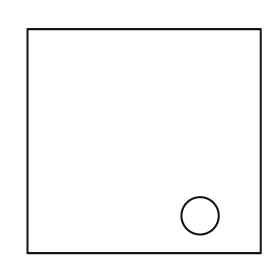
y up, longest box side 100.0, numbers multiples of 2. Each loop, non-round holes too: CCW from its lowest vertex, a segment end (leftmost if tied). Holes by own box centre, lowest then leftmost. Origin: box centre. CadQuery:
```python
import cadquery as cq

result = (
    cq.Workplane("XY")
    .moveTo(-50.0, -48.0)
    .lineTo(50.0, -48.0)
    .lineTo(50.0, 48.0)
    .lineTo(-50.0, 48.0)
    .close()
    .moveTo(24.0, -32.0)
    .circle(8.0)
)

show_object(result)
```